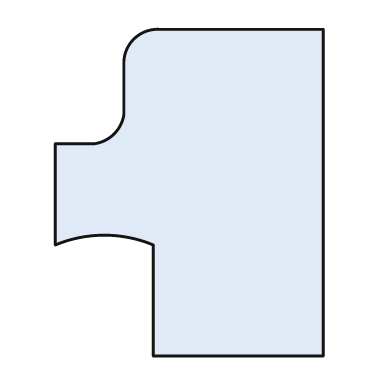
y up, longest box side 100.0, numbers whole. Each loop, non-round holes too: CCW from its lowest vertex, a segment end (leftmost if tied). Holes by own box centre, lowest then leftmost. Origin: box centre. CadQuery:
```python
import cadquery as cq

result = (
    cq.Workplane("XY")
    .moveTo(-11.0, -50.0)
    .lineTo(41.0, -50.0)
    .lineTo(41.0, 50.0)
    .lineTo(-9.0, 50.0)
    .threePointArc((-17.0, 47.0), (-20.0, 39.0))
    .lineTo(-20.0, 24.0)
    .threePointArc((-23.0, 18.0), (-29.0, 15.0))
    .lineTo(-41.0, 15.0)
    .lineTo(-41.0, -16.0)
    .threePointArc((-26.0, -13.0), (-11.0, -16.0))
    .close()
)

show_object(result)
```